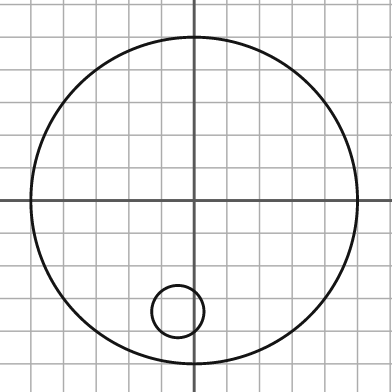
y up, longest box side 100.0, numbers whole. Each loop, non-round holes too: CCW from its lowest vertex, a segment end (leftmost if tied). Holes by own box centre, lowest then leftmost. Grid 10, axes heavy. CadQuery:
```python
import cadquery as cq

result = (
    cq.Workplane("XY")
    .moveTo(0.0, 0.0)
    .circle(50.0)
    .moveTo(-5.0, -34.0)
    .circle(8.0)
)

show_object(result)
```